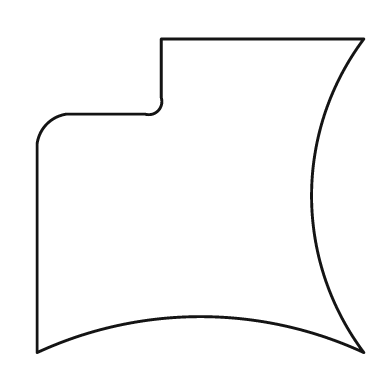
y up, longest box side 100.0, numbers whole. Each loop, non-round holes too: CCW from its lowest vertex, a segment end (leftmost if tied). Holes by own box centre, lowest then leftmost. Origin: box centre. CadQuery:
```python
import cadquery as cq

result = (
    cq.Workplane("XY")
    .moveTo(-50.0, -48.0)
    .threePointArc((0.0, -37.0), (50.0, -48.0))
    .threePointArc((34.0, 0.0), (50.0, 48.0))
    .lineTo(-12.0, 48.0)
    .lineTo(-12.0, 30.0)
    .threePointArc((-13.0, 26.0), (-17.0, 25.0))
    .lineTo(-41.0, 25.0)
    .threePointArc((-47.0, 22.0), (-50.0, 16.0))
    .close()
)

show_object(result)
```